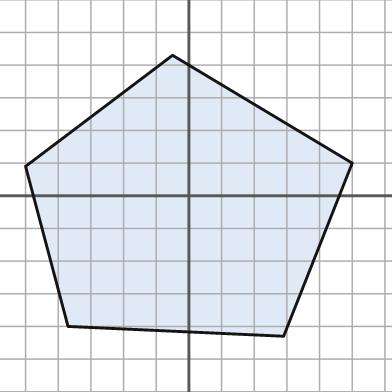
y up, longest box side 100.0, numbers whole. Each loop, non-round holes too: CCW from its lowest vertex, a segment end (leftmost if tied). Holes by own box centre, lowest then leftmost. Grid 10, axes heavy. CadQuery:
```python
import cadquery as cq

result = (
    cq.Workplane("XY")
    .moveTo(29.0, -43.0)
    .lineTo(50.0, 10.0)
    .lineTo(-5.0, 43.0)
    .lineTo(-50.0, 9.0)
    .lineTo(-37.0, -40.0)
    .close()
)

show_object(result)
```